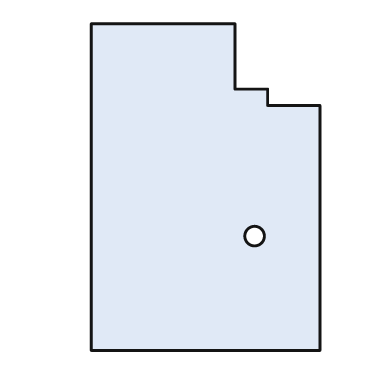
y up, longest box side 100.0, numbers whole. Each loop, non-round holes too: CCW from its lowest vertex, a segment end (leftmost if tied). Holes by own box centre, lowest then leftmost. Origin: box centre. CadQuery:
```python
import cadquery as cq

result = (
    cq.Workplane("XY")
    .moveTo(-35.0, -50.0)
    .lineTo(35.0, -50.0)
    .lineTo(35.0, 25.0)
    .lineTo(19.0, 25.0)
    .lineTo(19.0, 30.0)
    .lineTo(9.0, 30.0)
    .lineTo(9.0, 50.0)
    .lineTo(-35.0, 50.0)
    .close()
    .moveTo(15.0, -15.0)
    .circle(3.0)
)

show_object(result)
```